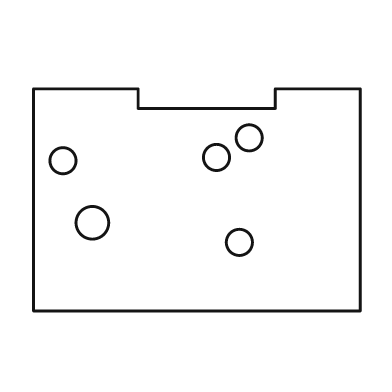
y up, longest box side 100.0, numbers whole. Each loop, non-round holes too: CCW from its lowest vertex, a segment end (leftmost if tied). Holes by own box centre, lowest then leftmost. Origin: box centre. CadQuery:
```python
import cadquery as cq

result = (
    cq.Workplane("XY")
    .moveTo(-50.0, -34.0)
    .lineTo(50.0, -34.0)
    .lineTo(50.0, 34.0)
    .lineTo(24.0, 34.0)
    .lineTo(24.0, 28.0)
    .lineTo(-18.0, 28.0)
    .lineTo(-18.0, 34.0)
    .lineTo(-50.0, 34.0)
    .close()
    .moveTo(13.0, -13.0)
    .circle(4.0)
    .moveTo(-32.0, -7.0)
    .circle(5.0)
    .moveTo(-41.0, 12.0)
    .circle(4.0)
    .moveTo(6.0, 13.0)
    .circle(4.0)
    .moveTo(16.0, 19.0)
    .circle(4.0)
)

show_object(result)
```